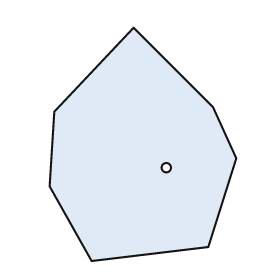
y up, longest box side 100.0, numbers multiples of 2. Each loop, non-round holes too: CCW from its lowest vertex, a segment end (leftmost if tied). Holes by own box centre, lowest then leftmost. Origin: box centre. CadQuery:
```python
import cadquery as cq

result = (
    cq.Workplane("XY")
    .moveTo(-22.0, -50.0)
    .lineTo(28.0, -44.0)
    .lineTo(40.0, -6.0)
    .lineTo(30.0, 16.0)
    .lineTo(-4.0, 50.0)
    .lineTo(-38.0, 14.0)
    .lineTo(-40.0, -18.0)
    .close()
    .moveTo(10.0, -10.0)
    .circle(2.0)
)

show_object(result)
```